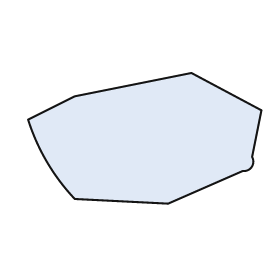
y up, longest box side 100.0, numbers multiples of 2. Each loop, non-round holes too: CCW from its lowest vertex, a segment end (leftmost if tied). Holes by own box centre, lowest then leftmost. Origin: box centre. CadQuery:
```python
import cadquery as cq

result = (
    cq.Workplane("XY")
    .moveTo(10.0, -28.0)
    .lineTo(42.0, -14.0)
    .threePointArc((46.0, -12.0), (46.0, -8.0))
    .lineTo(50.0, 12.0)
    .lineTo(20.0, 28.0)
    .lineTo(-30.0, 18.0)
    .lineTo(-50.0, 8.0)
    .threePointArc((-42.0, -10.0), (-30.0, -26.0))
    .close()
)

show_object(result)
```